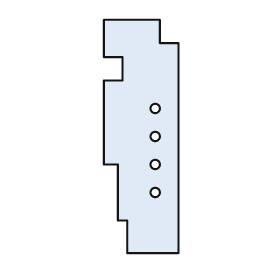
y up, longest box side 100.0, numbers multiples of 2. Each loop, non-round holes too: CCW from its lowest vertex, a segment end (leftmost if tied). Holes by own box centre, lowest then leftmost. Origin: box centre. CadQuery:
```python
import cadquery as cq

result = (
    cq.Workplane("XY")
    .moveTo(-6.0, -50.0)
    .lineTo(16.0, -50.0)
    .lineTo(16.0, 40.0)
    .lineTo(8.0, 40.0)
    .lineTo(8.0, 50.0)
    .lineTo(-16.0, 50.0)
    .lineTo(-16.0, 34.0)
    .lineTo(-8.0, 34.0)
    .lineTo(-8.0, 24.0)
    .lineTo(-16.0, 24.0)
    .lineTo(-16.0, -12.0)
    .lineTo(-10.0, -12.0)
    .lineTo(-10.0, -36.0)
    .lineTo(-6.0, -36.0)
    .close()
    .moveTo(6.0, -24.0)
    .circle(2.0)
    .moveTo(6.0, -12.0)
    .circle(2.0)
    .moveTo(6.0, 0.0)
    .circle(2.0)
    .moveTo(6.0, 12.0)
    .circle(2.0)
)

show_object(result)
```